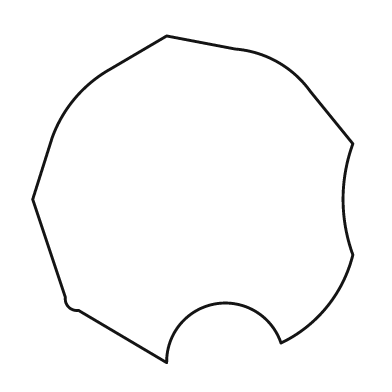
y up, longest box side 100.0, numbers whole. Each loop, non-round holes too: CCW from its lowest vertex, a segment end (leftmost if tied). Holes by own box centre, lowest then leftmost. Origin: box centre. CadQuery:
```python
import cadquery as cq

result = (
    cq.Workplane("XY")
    .moveTo(-8.0, -50.0)
    .threePointArc((7.0, -32.0), (27.0, -44.0))
    .threePointArc((41.0, -33.0), (49.0, -17.0))
    .threePointArc((46.0, 0.0), (49.0, 17.0))
    .lineTo(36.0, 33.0)
    .threePointArc((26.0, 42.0), (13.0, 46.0))
    .lineTo(-8.0, 50.0)
    .lineTo(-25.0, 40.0)
    .threePointArc((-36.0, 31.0), (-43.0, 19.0))
    .lineTo(-49.0, 0.0)
    .lineTo(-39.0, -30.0)
    .threePointArc((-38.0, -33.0), (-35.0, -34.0))
    .close()
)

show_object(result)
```